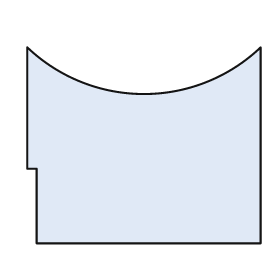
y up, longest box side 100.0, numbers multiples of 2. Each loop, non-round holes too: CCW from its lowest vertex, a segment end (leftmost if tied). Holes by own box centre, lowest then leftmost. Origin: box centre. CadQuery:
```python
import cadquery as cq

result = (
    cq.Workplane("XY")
    .moveTo(-46.0, -42.0)
    .lineTo(50.0, -42.0)
    .lineTo(50.0, 42.0)
    .threePointArc((0.0, 22.0), (-50.0, 42.0))
    .lineTo(-50.0, -10.0)
    .lineTo(-46.0, -10.0)
    .close()
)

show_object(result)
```